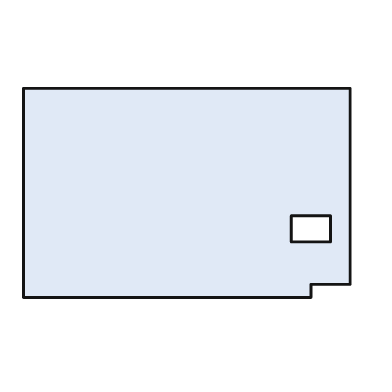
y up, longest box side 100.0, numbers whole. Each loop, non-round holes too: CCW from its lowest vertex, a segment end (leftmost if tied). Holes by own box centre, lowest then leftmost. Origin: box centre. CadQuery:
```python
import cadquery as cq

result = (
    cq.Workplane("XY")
    .moveTo(-50.0, -32.0)
    .lineTo(38.0, -32.0)
    .lineTo(38.0, -28.0)
    .lineTo(50.0, -28.0)
    .lineTo(50.0, 32.0)
    .lineTo(-50.0, 32.0)
    .close()
    .moveTo(32.0, -15.0)
    .lineTo(44.0, -15.0)
    .lineTo(44.0, -7.0)
    .lineTo(32.0, -7.0)
    .close()
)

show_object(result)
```